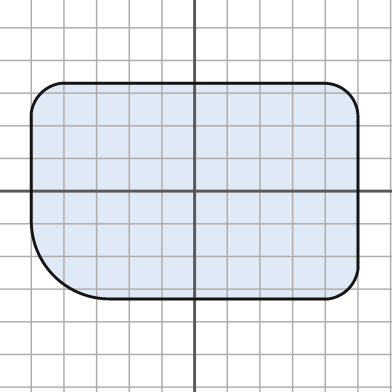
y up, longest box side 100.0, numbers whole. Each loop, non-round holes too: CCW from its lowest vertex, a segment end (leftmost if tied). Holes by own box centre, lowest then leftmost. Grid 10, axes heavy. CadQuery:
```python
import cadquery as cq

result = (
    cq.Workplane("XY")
    .moveTo(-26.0, -33.0)
    .lineTo(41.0, -33.0)
    .threePointArc((47.0, -30.0), (50.0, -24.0))
    .lineTo(50.0, 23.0)
    .threePointArc((47.0, 30.0), (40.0, 33.0))
    .lineTo(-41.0, 33.0)
    .threePointArc((-47.0, 30.0), (-50.0, 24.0))
    .lineTo(-50.0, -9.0)
    .threePointArc((-43.0, -26.0), (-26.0, -33.0))
    .close()
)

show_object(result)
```